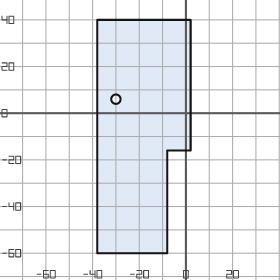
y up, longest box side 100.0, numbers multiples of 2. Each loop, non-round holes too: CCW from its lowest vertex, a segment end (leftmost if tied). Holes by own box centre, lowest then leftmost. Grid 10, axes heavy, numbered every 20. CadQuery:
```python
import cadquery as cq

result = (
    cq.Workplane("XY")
    .moveTo(-38.0, -60.0)
    .lineTo(-8.0, -60.0)
    .lineTo(-8.0, -16.0)
    .lineTo(2.0, -16.0)
    .lineTo(2.0, 40.0)
    .lineTo(-38.0, 40.0)
    .close()
    .moveTo(-30.0, 6.0)
    .circle(2.0)
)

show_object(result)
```